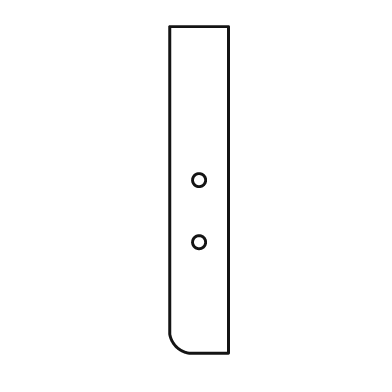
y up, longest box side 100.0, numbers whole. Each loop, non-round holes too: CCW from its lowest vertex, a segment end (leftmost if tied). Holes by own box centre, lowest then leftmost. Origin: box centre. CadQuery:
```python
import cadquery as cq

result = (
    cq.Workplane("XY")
    .moveTo(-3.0, -50.0)
    .lineTo(9.0, -50.0)
    .lineTo(9.0, 50.0)
    .lineTo(-9.0, 50.0)
    .lineTo(-9.0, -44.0)
    .threePointArc((-7.0, -48.0), (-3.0, -50.0))
    .close()
    .moveTo(0.0, -16.0)
    .circle(2.0)
    .moveTo(0.0, 3.0)
    .circle(2.0)
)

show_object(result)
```